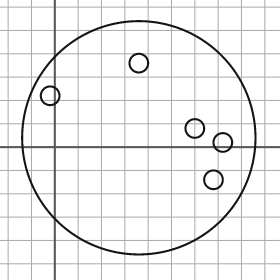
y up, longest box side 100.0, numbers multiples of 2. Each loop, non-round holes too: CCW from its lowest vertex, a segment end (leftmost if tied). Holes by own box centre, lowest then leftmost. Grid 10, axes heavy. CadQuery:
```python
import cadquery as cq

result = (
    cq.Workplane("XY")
    .moveTo(36.0, 4.0)
    .circle(50.0)
    .moveTo(68.0, -14.0)
    .circle(4.0)
    .moveTo(72.0, 2.0)
    .circle(4.0)
    .moveTo(60.0, 8.0)
    .circle(4.0)
    .moveTo(-2.0, 22.0)
    .circle(4.0)
    .moveTo(36.0, 36.0)
    .circle(4.0)
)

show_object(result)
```